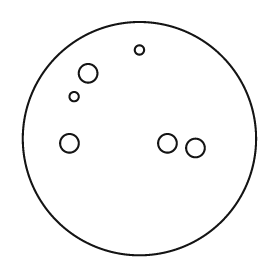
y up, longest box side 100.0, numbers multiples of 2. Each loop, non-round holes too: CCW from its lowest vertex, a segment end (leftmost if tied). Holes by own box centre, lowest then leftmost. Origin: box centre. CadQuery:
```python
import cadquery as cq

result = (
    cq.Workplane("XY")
    .moveTo(0.0, 0.0)
    .circle(50.0)
    .moveTo(24.0, -4.0)
    .circle(4.0)
    .moveTo(-30.0, -2.0)
    .circle(4.0)
    .moveTo(12.0, -2.0)
    .circle(4.0)
    .moveTo(-28.0, 18.0)
    .circle(2.0)
    .moveTo(-22.0, 28.0)
    .circle(4.0)
    .moveTo(0.0, 38.0)
    .circle(2.0)
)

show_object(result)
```